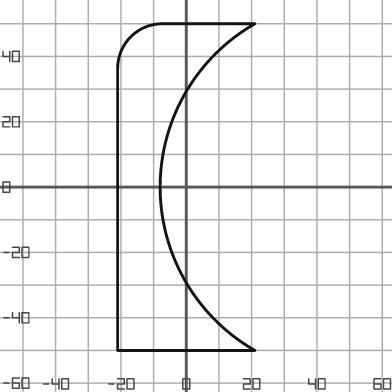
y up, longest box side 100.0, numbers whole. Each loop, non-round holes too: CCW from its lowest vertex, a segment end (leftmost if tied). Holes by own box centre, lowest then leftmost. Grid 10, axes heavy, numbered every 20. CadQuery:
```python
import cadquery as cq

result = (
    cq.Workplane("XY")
    .moveTo(-21.0, -50.0)
    .lineTo(21.0, -50.0)
    .threePointArc((-8.0, 0.0), (21.0, 50.0))
    .lineTo(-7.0, 50.0)
    .threePointArc((-17.0, 46.0), (-21.0, 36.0))
    .close()
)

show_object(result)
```